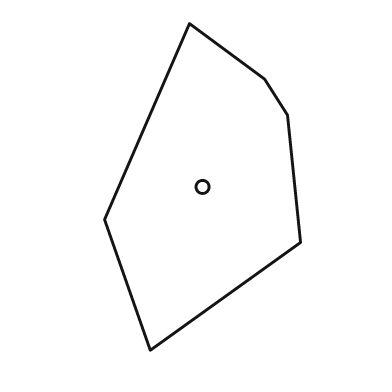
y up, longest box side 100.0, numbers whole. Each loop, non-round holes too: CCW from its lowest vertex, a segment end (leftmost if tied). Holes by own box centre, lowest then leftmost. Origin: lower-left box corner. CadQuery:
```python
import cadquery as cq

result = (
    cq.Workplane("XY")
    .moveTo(14.0, 0.0)
    .lineTo(60.0, 33.0)
    .lineTo(56.0, 72.0)
    .lineTo(49.0, 83.0)
    .lineTo(26.0, 100.0)
    .lineTo(0.0, 40.0)
    .close()
    .moveTo(30.0, 50.0)
    .circle(2.0)
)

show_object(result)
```